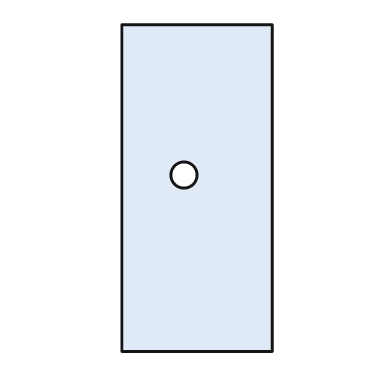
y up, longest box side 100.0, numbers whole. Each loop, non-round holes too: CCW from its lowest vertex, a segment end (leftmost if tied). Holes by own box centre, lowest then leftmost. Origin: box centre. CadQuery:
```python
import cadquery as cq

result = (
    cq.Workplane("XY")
    .moveTo(-23.0, -50.0)
    .lineTo(23.0, -50.0)
    .lineTo(23.0, 50.0)
    .lineTo(-23.0, 50.0)
    .close()
    .moveTo(-4.0, 4.0)
    .circle(4.0)
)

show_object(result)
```